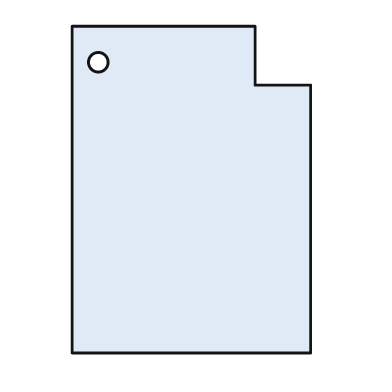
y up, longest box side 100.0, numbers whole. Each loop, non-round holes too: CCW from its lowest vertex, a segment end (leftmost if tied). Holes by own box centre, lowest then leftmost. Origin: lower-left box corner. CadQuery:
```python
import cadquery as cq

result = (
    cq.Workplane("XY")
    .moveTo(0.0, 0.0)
    .lineTo(73.0, 0.0)
    .lineTo(73.0, 82.0)
    .lineTo(56.0, 82.0)
    .lineTo(56.0, 100.0)
    .lineTo(0.0, 100.0)
    .close()
    .moveTo(8.0, 89.0)
    .circle(3.0)
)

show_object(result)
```